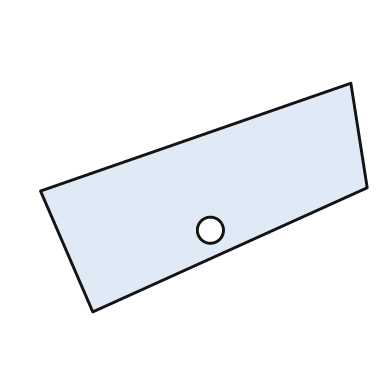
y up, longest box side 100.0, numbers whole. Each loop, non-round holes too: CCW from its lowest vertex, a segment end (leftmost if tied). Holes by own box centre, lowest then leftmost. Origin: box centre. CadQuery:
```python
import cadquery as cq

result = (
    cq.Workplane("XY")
    .moveTo(-34.0, -35.0)
    .lineTo(50.0, 3.0)
    .lineTo(45.0, 35.0)
    .lineTo(-50.0, 2.0)
    .close()
    .moveTo(2.0, -10.0)
    .circle(4.0)
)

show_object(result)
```